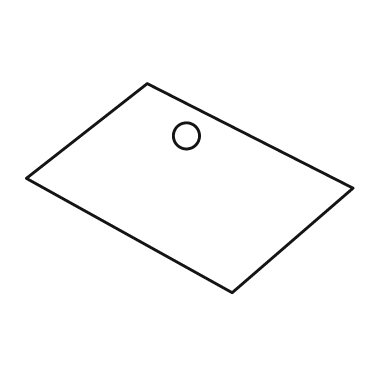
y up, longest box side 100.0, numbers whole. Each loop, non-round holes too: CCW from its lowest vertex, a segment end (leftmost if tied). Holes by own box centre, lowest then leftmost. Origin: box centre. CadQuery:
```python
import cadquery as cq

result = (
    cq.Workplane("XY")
    .moveTo(13.0, -32.0)
    .lineTo(50.0, 0.0)
    .lineTo(-13.0, 32.0)
    .lineTo(-50.0, 3.0)
    .close()
    .moveTo(-1.0, 16.0)
    .circle(4.0)
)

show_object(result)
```